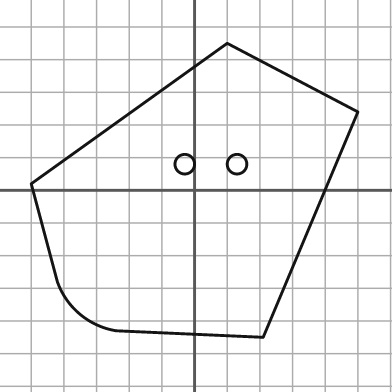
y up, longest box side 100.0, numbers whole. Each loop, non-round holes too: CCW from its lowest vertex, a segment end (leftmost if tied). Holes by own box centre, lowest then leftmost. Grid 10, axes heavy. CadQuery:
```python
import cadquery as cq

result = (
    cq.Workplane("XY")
    .moveTo(21.0, -45.0)
    .lineTo(50.0, 24.0)
    .lineTo(10.0, 45.0)
    .lineTo(-50.0, 2.0)
    .lineTo(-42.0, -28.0)
    .threePointArc((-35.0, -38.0), (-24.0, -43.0))
    .close()
    .moveTo(-3.0, 8.0)
    .circle(3.0)
    .moveTo(13.0, 8.0)
    .circle(3.0)
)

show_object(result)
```